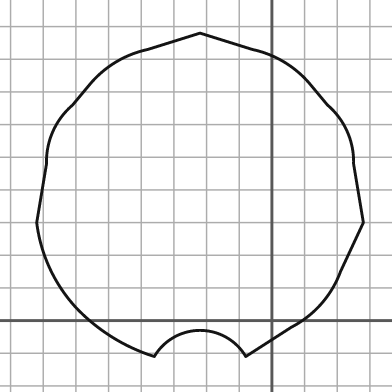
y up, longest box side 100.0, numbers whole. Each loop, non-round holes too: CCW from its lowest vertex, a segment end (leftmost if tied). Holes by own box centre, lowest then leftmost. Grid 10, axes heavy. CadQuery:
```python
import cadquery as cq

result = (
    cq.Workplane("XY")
    .moveTo(-36.0, -11.0)
    .threePointArc((-22.0, -3.0), (-8.0, -11.0))
    .lineTo(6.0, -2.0)
    .threePointArc((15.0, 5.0), (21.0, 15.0))
    .lineTo(28.0, 30.0)
    .lineTo(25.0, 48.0)
    .threePointArc((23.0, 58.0), (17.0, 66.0))
    .lineTo(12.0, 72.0)
    .threePointArc((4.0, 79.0), (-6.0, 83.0))
    .lineTo(-22.0, 88.0)
    .lineTo(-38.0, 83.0)
    .threePointArc((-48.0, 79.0), (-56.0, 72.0))
    .lineTo(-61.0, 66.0)
    .threePointArc((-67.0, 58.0), (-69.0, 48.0))
    .lineTo(-72.0, 30.0)
    .threePointArc((-68.0, 16.0), (-60.0, 4.0))
    .threePointArc((-49.0, -5.0), (-36.0, -11.0))
    .close()
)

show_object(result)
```